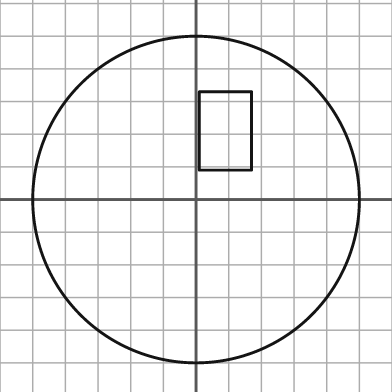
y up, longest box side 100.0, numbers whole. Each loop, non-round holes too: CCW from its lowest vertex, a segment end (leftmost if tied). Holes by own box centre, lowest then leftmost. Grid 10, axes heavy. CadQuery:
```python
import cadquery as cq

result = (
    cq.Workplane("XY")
    .moveTo(0.0, 0.0)
    .circle(50.0)
    .moveTo(1.0, 9.0)
    .lineTo(17.0, 9.0)
    .lineTo(17.0, 33.0)
    .lineTo(1.0, 33.0)
    .close()
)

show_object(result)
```